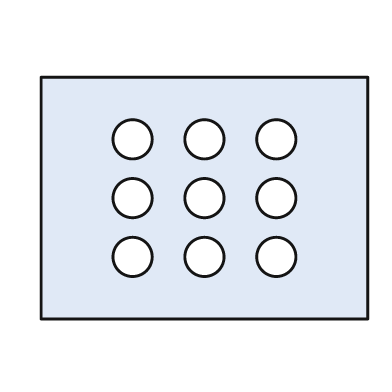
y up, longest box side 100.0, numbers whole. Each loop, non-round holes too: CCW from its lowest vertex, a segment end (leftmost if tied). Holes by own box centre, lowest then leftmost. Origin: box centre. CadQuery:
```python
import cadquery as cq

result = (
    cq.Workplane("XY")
    .moveTo(-50.0, -37.0)
    .lineTo(50.0, -37.0)
    .lineTo(50.0, 37.0)
    .lineTo(-50.0, 37.0)
    .close()
    .moveTo(-22.0, -18.0)
    .circle(6.0)
    .moveTo(0.0, -18.0)
    .circle(6.0)
    .moveTo(22.0, -18.0)
    .circle(6.0)
    .moveTo(-22.0, 0.0)
    .circle(6.0)
    .moveTo(0.0, 0.0)
    .circle(6.0)
    .moveTo(22.0, 0.0)
    .circle(6.0)
    .moveTo(-22.0, 18.0)
    .circle(6.0)
    .moveTo(0.0, 18.0)
    .circle(6.0)
    .moveTo(22.0, 18.0)
    .circle(6.0)
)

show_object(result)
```